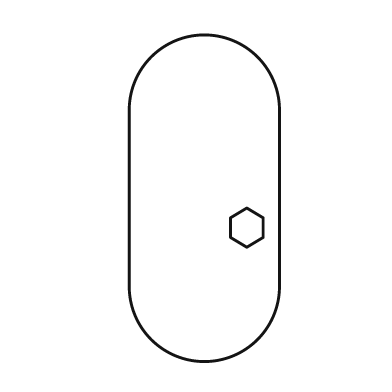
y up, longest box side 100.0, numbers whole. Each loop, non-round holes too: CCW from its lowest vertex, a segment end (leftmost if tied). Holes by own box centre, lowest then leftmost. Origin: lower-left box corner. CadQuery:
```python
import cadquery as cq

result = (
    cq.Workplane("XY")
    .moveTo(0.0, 23.0)
    .threePointArc((23.0, 0.0), (46.0, 23.0))
    .lineTo(46.0, 77.0)
    .threePointArc((23.0, 100.0), (0.0, 77.0))
    .close()
    .moveTo(36.0, 35.0)
    .lineTo(41.0, 38.0)
    .lineTo(41.0, 44.0)
    .lineTo(36.0, 47.0)
    .lineTo(31.0, 44.0)
    .lineTo(31.0, 38.0)
    .close()
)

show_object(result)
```